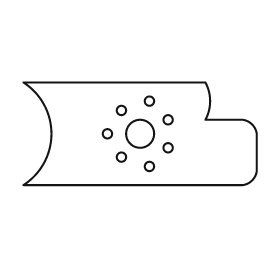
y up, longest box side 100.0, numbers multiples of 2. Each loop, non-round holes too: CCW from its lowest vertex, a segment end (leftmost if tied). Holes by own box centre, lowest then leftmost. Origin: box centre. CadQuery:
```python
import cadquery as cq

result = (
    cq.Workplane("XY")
    .moveTo(-50.0, -22.0)
    .lineTo(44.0, -22.0)
    .threePointArc((48.0, -20.0), (50.0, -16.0))
    .lineTo(50.0, 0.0)
    .threePointArc((48.0, 4.0), (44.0, 6.0))
    .lineTo(28.0, 6.0)
    .threePointArc((30.0, 14.0), (28.0, 22.0))
    .lineTo(-50.0, 22.0)
    .threePointArc((-38.0, 0.0), (-50.0, -22.0))
    .close()
    .moveTo(4.0, -14.0)
    .circle(2.0)
    .moveTo(-8.0, -10.0)
    .circle(2.0)
    .moveTo(12.0, -6.0)
    .circle(2.0)
    .moveTo(-14.0, 0.0)
    .circle(2.0)
    .moveTo(0.0, 0.0)
    .circle(6.0)
    .moveTo(12.0, 6.0)
    .circle(2.0)
    .moveTo(-8.0, 10.0)
    .circle(2.0)
    .moveTo(4.0, 14.0)
    .circle(2.0)
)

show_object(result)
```